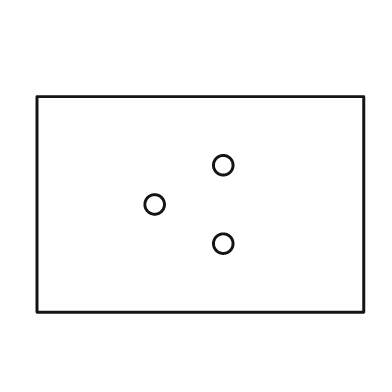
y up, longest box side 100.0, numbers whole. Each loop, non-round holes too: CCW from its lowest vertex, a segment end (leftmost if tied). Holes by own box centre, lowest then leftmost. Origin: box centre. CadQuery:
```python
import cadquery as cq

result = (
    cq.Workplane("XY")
    .moveTo(-50.0, -33.0)
    .lineTo(50.0, -33.0)
    .lineTo(50.0, 33.0)
    .lineTo(-50.0, 33.0)
    .close()
    .moveTo(7.0, -12.0)
    .circle(3.0)
    .moveTo(-14.0, 0.0)
    .circle(3.0)
    .moveTo(7.0, 12.0)
    .circle(3.0)
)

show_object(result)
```